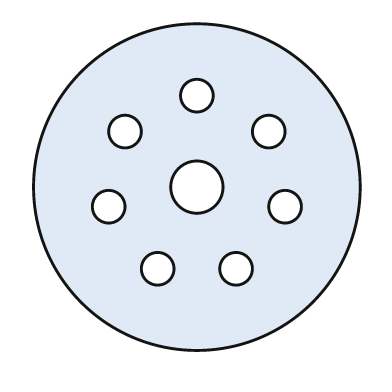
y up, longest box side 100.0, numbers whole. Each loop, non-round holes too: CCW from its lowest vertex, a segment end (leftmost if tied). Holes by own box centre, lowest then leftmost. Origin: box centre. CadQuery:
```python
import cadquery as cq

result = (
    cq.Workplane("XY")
    .moveTo(0.0, 0.0)
    .circle(50.0)
    .moveTo(-12.0, -25.0)
    .circle(5.0)
    .moveTo(12.0, -25.0)
    .circle(5.0)
    .moveTo(-27.0, -6.0)
    .circle(5.0)
    .moveTo(27.0, -6.0)
    .circle(5.0)
    .moveTo(0.0, 0.0)
    .circle(8.0)
    .moveTo(-22.0, 17.0)
    .circle(5.0)
    .moveTo(22.0, 17.0)
    .circle(5.0)
    .moveTo(0.0, 28.0)
    .circle(5.0)
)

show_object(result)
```